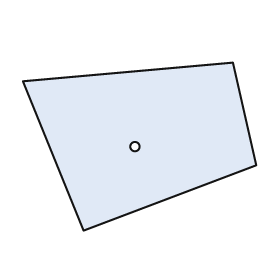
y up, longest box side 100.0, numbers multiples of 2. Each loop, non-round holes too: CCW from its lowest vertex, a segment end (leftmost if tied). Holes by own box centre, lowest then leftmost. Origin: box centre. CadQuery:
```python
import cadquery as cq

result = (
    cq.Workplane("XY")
    .moveTo(-24.0, -36.0)
    .lineTo(50.0, -8.0)
    .lineTo(40.0, 36.0)
    .lineTo(-50.0, 28.0)
    .close()
    .moveTo(-2.0, 0.0)
    .circle(2.0)
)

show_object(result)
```